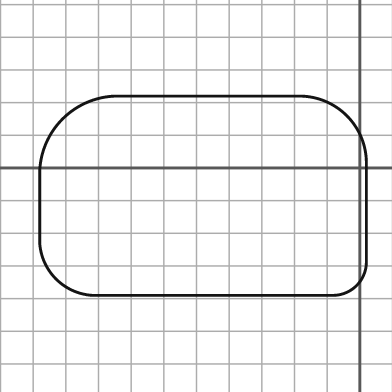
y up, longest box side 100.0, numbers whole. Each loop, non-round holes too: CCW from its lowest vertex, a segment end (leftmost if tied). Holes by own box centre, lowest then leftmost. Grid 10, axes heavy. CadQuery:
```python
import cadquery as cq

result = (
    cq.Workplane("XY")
    .moveTo(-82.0, -39.0)
    .lineTo(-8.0, -39.0)
    .threePointArc((-1.0, -36.0), (2.0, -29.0))
    .lineTo(2.0, 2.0)
    .threePointArc((-4.0, 16.0), (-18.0, 22.0))
    .lineTo(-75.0, 22.0)
    .threePointArc((-91.0, 15.0), (-98.0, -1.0))
    .lineTo(-98.0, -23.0)
    .threePointArc((-93.0, -34.0), (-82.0, -39.0))
    .close()
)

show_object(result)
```